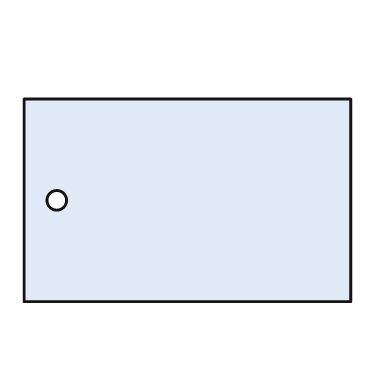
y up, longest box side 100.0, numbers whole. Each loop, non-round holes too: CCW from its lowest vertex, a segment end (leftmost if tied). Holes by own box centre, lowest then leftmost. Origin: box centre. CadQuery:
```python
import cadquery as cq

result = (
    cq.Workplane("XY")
    .moveTo(-50.0, -31.0)
    .lineTo(50.0, -31.0)
    .lineTo(50.0, 31.0)
    .lineTo(-50.0, 31.0)
    .close()
    .moveTo(-40.0, 0.0)
    .circle(3.0)
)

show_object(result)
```